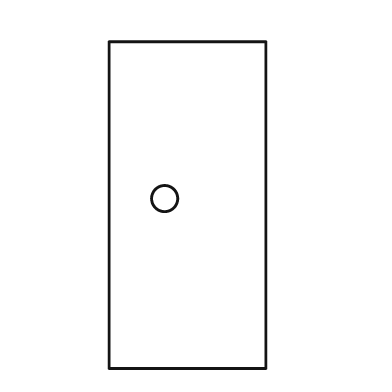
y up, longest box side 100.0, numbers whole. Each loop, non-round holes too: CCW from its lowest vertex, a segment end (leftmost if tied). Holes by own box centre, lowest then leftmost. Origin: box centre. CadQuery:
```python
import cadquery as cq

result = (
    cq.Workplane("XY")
    .moveTo(-24.0, -50.0)
    .lineTo(24.0, -50.0)
    .lineTo(24.0, 50.0)
    .lineTo(-24.0, 50.0)
    .close()
    .moveTo(-7.0, 2.0)
    .circle(4.0)
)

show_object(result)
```